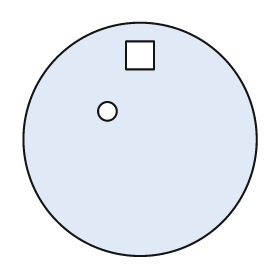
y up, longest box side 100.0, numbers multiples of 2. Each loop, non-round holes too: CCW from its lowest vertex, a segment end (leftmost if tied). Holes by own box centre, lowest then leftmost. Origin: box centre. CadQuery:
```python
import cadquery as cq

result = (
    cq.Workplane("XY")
    .moveTo(0.0, 0.0)
    .circle(50.0)
    .moveTo(-14.0, 12.0)
    .circle(4.0)
    .moveTo(-6.0, 30.0)
    .lineTo(6.0, 30.0)
    .lineTo(6.0, 42.0)
    .lineTo(-6.0, 42.0)
    .close()
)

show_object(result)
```